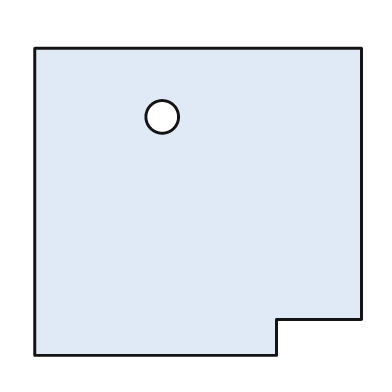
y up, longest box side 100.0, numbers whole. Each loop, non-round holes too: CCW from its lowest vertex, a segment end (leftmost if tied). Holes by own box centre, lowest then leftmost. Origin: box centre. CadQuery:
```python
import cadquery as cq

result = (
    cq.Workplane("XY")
    .moveTo(-50.0, -47.0)
    .lineTo(24.0, -47.0)
    .lineTo(24.0, -36.0)
    .lineTo(50.0, -36.0)
    .lineTo(50.0, 47.0)
    .lineTo(-50.0, 47.0)
    .close()
    .moveTo(-11.0, 26.0)
    .circle(5.0)
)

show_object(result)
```